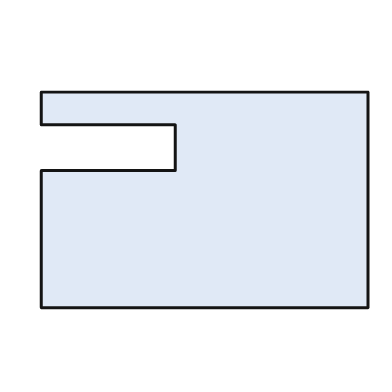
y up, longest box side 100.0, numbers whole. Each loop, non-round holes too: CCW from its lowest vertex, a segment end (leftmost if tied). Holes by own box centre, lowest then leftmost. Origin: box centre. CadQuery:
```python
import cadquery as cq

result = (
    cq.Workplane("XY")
    .moveTo(-50.0, -33.0)
    .lineTo(50.0, -33.0)
    .lineTo(50.0, 33.0)
    .lineTo(-50.0, 33.0)
    .lineTo(-50.0, 23.0)
    .lineTo(-9.0, 23.0)
    .lineTo(-9.0, 9.0)
    .lineTo(-50.0, 9.0)
    .close()
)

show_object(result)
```